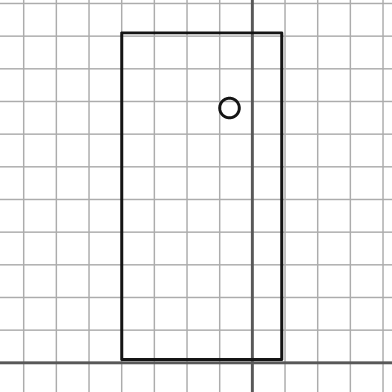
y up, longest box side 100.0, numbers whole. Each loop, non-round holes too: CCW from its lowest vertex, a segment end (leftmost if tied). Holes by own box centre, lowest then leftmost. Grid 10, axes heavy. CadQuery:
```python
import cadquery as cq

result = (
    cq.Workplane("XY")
    .moveTo(-40.0, 1.0)
    .lineTo(9.0, 1.0)
    .lineTo(9.0, 101.0)
    .lineTo(-40.0, 101.0)
    .close()
    .moveTo(-7.0, 78.0)
    .circle(3.0)
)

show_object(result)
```